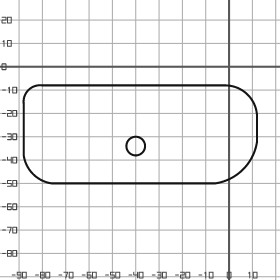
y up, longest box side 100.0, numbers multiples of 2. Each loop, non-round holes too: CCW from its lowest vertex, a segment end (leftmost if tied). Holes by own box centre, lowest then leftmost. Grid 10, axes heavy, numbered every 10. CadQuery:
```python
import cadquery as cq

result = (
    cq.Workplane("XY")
    .moveTo(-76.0, -50.0)
    .lineTo(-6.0, -50.0)
    .threePointArc((6.0, -44.0), (12.0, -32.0))
    .lineTo(12.0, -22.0)
    .threePointArc((8.0, -12.0), (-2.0, -8.0))
    .lineTo(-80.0, -8.0)
    .threePointArc((-86.0, -10.0), (-88.0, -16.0))
    .lineTo(-88.0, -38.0)
    .threePointArc((-84.0, -46.0), (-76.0, -50.0))
    .close()
    .moveTo(-40.0, -34.0)
    .circle(4.0)
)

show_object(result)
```